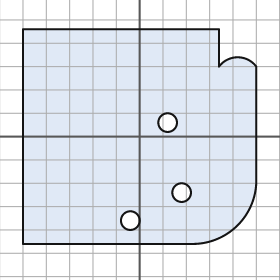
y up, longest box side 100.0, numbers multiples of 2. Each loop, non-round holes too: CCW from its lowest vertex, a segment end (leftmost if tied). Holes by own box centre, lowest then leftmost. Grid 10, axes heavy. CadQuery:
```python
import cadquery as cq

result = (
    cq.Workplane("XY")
    .moveTo(-50.0, -46.0)
    .lineTo(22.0, -46.0)
    .threePointArc((42.0, -38.0), (50.0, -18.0))
    .lineTo(50.0, 30.0)
    .threePointArc((42.0, 34.0), (34.0, 30.0))
    .lineTo(34.0, 46.0)
    .lineTo(-50.0, 46.0)
    .close()
    .moveTo(-4.0, -36.0)
    .circle(4.0)
    .moveTo(18.0, -24.0)
    .circle(4.0)
    .moveTo(12.0, 6.0)
    .circle(4.0)
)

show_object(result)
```